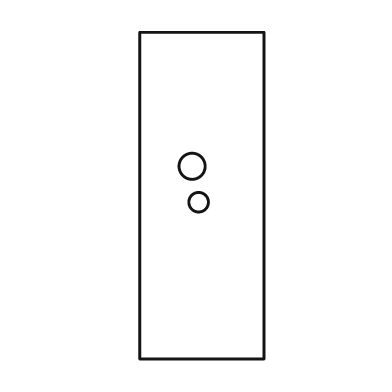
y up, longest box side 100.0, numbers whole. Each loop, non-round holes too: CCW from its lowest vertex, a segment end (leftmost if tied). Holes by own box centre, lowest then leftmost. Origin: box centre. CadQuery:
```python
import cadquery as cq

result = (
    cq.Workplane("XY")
    .moveTo(-19.0, -50.0)
    .lineTo(19.0, -50.0)
    .lineTo(19.0, 50.0)
    .lineTo(-19.0, 50.0)
    .close()
    .moveTo(-1.0, -2.0)
    .circle(3.0)
    .moveTo(-3.0, 9.0)
    .circle(4.0)
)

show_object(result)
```